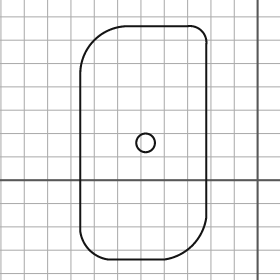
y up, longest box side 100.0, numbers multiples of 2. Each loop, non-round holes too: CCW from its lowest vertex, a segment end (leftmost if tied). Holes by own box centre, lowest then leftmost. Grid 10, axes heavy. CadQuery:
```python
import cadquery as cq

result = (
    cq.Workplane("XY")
    .moveTo(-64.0, -34.0)
    .lineTo(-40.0, -34.0)
    .threePointArc((-28.0, -28.0), (-22.0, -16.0))
    .lineTo(-22.0, 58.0)
    .threePointArc((-24.0, 64.0), (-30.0, 66.0))
    .lineTo(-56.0, 66.0)
    .threePointArc((-70.0, 60.0), (-76.0, 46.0))
    .lineTo(-76.0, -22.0)
    .threePointArc((-72.0, -30.0), (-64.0, -34.0))
    .close()
    .moveTo(-48.0, 16.0)
    .circle(4.0)
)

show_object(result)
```